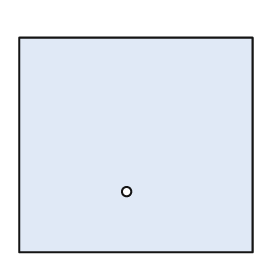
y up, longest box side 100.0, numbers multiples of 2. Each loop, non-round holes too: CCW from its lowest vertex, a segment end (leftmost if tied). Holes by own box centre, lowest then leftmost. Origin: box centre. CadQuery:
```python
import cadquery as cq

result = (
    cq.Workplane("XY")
    .moveTo(-50.0, -46.0)
    .lineTo(50.0, -46.0)
    .lineTo(50.0, 46.0)
    .lineTo(-50.0, 46.0)
    .close()
    .moveTo(-4.0, -20.0)
    .circle(2.0)
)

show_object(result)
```